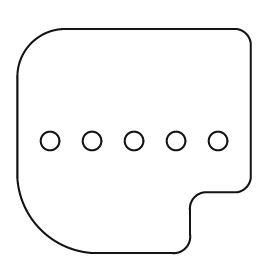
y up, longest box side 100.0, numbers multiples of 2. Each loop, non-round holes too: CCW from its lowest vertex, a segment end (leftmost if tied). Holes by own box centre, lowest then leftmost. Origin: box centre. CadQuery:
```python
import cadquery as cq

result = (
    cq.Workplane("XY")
    .moveTo(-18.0, -48.0)
    .lineTo(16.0, -48.0)
    .threePointArc((22.0, -46.0), (24.0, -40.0))
    .lineTo(24.0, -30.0)
    .threePointArc((26.0, -24.0), (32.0, -22.0))
    .lineTo(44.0, -22.0)
    .threePointArc((48.0, -20.0), (50.0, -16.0))
    .lineTo(50.0, 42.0)
    .threePointArc((48.0, 46.0), (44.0, 48.0))
    .lineTo(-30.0, 48.0)
    .threePointArc((-44.0, 42.0), (-50.0, 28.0))
    .lineTo(-50.0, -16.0)
    .threePointArc((-40.0, -38.0), (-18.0, -48.0))
    .close()
    .moveTo(-36.0, 0.0)
    .circle(4.0)
    .moveTo(-18.0, 0.0)
    .circle(4.0)
    .moveTo(0.0, 0.0)
    .circle(4.0)
    .moveTo(18.0, 0.0)
    .circle(4.0)
    .moveTo(36.0, 0.0)
    .circle(4.0)
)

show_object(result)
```